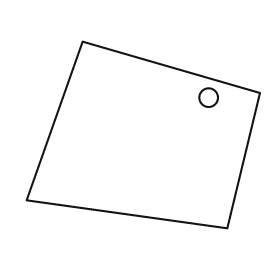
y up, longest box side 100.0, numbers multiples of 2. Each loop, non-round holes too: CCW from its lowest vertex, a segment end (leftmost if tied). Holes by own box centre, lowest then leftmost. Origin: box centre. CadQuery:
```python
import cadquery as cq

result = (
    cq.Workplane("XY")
    .moveTo(36.0, -40.0)
    .lineTo(50.0, 18.0)
    .lineTo(-26.0, 40.0)
    .lineTo(-50.0, -28.0)
    .close()
    .moveTo(28.0, 16.0)
    .circle(4.0)
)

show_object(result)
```